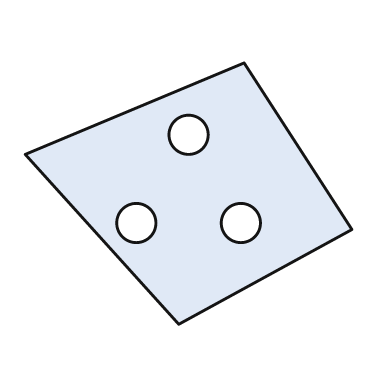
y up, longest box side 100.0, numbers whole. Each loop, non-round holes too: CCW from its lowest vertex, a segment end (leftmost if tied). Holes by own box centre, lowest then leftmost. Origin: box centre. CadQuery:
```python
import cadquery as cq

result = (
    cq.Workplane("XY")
    .moveTo(-3.0, -40.0)
    .lineTo(50.0, -11.0)
    .lineTo(17.0, 40.0)
    .lineTo(-50.0, 12.0)
    .close()
    .moveTo(-16.0, -9.0)
    .circle(6.0)
    .moveTo(16.0, -9.0)
    .circle(6.0)
    .moveTo(0.0, 18.0)
    .circle(6.0)
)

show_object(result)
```